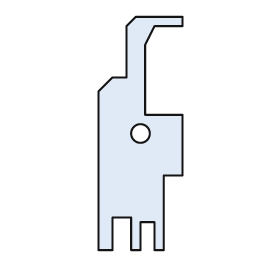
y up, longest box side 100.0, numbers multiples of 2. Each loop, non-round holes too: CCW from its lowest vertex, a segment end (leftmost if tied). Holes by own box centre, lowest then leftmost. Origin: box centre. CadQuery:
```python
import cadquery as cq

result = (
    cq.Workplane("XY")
    .moveTo(-18.0, -50.0)
    .lineTo(-12.0, -50.0)
    .lineTo(-12.0, -36.0)
    .lineTo(-4.0, -36.0)
    .lineTo(-4.0, -50.0)
    .lineTo(0.0, -50.0)
    .lineTo(0.0, -38.0)
    .lineTo(6.0, -38.0)
    .lineTo(6.0, -50.0)
    .lineTo(10.0, -50.0)
    .lineTo(10.0, -18.0)
    .lineTo(18.0, -18.0)
    .lineTo(18.0, 8.0)
    .lineTo(2.0, 8.0)
    .lineTo(2.0, 38.0)
    .lineTo(6.0, 46.0)
    .lineTo(18.0, 46.0)
    .lineTo(18.0, 50.0)
    .lineTo(-2.0, 50.0)
    .lineTo(-6.0, 46.0)
    .lineTo(-6.0, 24.0)
    .lineTo(-12.0, 24.0)
    .lineTo(-18.0, 18.0)
    .close()
    .moveTo(0.0, 0.0)
    .circle(4.0)
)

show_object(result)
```